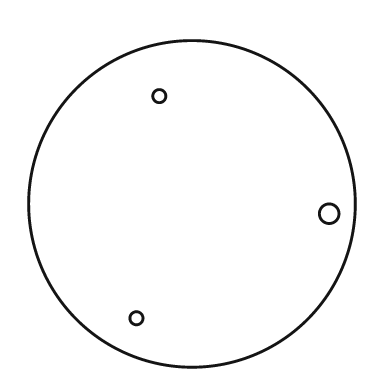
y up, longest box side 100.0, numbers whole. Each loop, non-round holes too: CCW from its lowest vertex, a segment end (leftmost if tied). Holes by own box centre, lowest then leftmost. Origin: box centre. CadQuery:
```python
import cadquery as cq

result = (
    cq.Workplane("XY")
    .moveTo(0.0, 0.0)
    .circle(50.0)
    .moveTo(-17.0, -35.0)
    .circle(2.0)
    .moveTo(42.0, -3.0)
    .circle(3.0)
    .moveTo(-10.0, 33.0)
    .circle(2.0)
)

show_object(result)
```